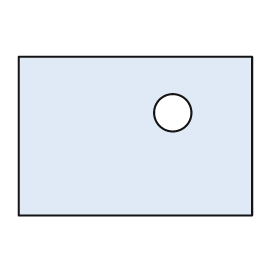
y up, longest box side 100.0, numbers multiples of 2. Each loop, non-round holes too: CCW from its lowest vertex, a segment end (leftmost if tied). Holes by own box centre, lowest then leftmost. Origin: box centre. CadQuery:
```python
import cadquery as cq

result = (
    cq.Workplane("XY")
    .moveTo(-50.0, -34.0)
    .lineTo(50.0, -34.0)
    .lineTo(50.0, 34.0)
    .lineTo(-50.0, 34.0)
    .close()
    .moveTo(16.0, 10.0)
    .circle(8.0)
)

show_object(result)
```